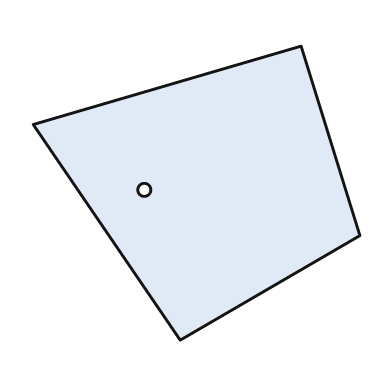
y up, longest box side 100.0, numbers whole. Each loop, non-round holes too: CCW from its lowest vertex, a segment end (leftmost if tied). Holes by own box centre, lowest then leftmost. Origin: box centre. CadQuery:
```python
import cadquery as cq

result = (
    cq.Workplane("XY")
    .moveTo(-5.0, -45.0)
    .lineTo(50.0, -13.0)
    .lineTo(32.0, 45.0)
    .lineTo(-50.0, 21.0)
    .close()
    .moveTo(-16.0, 1.0)
    .circle(2.0)
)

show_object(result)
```